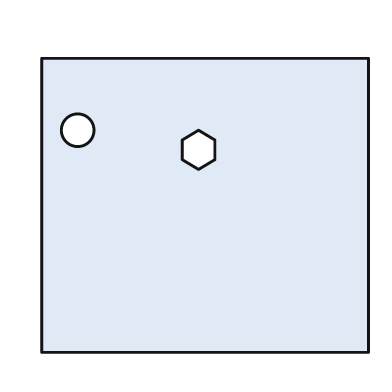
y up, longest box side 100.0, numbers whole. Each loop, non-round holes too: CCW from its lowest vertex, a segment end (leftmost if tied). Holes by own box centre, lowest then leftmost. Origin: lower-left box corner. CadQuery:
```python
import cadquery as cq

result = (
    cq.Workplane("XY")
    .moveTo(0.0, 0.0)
    .lineTo(100.0, 0.0)
    .lineTo(100.0, 90.0)
    .lineTo(0.0, 90.0)
    .close()
    .moveTo(48.0, 56.0)
    .lineTo(53.0, 59.0)
    .lineTo(53.0, 65.0)
    .lineTo(48.0, 68.0)
    .lineTo(43.0, 65.0)
    .lineTo(43.0, 59.0)
    .close()
    .moveTo(11.0, 68.0)
    .circle(5.0)
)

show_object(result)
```